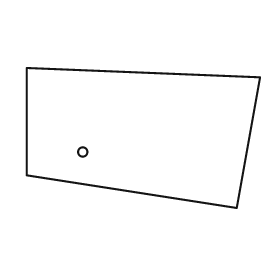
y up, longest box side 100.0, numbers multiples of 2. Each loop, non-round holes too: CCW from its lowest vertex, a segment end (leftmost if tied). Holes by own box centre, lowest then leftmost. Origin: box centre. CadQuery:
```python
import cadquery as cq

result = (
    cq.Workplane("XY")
    .moveTo(40.0, -30.0)
    .lineTo(50.0, 26.0)
    .lineTo(-50.0, 30.0)
    .lineTo(-50.0, -16.0)
    .close()
    .moveTo(-26.0, -6.0)
    .circle(2.0)
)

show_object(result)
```